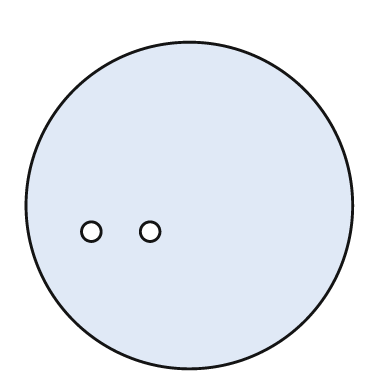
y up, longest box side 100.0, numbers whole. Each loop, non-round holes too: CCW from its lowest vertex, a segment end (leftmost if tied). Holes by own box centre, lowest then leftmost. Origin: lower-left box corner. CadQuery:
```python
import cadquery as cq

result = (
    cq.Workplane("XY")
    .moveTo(50.0, 50.0)
    .circle(50.0)
    .moveTo(20.0, 42.0)
    .circle(3.0)
    .moveTo(38.0, 42.0)
    .circle(3.0)
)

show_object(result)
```